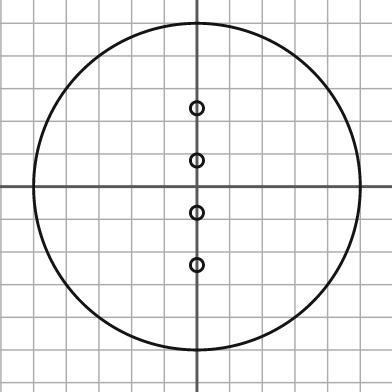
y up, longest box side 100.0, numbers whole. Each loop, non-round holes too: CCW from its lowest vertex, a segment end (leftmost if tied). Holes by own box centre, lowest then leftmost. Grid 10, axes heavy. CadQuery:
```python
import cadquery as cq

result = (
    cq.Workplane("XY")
    .moveTo(0.0, 0.0)
    .circle(50.0)
    .moveTo(0.0, -24.0)
    .circle(2.0)
    .moveTo(0.0, -8.0)
    .circle(2.0)
    .moveTo(0.0, 8.0)
    .circle(2.0)
    .moveTo(0.0, 24.0)
    .circle(2.0)
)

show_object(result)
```